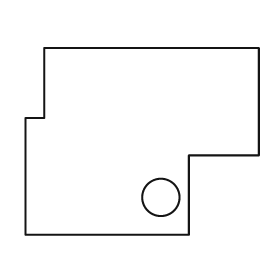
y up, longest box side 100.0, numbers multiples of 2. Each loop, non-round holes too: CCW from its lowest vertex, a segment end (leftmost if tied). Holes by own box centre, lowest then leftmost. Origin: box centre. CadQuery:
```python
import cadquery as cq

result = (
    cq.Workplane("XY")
    .moveTo(-50.0, -40.0)
    .lineTo(20.0, -40.0)
    .lineTo(20.0, -6.0)
    .lineTo(50.0, -6.0)
    .lineTo(50.0, 40.0)
    .lineTo(-42.0, 40.0)
    .lineTo(-42.0, 10.0)
    .lineTo(-50.0, 10.0)
    .close()
    .moveTo(8.0, -24.0)
    .circle(8.0)
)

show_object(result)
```